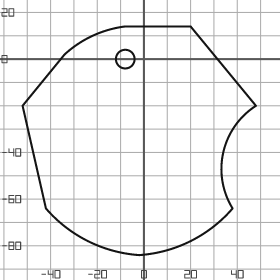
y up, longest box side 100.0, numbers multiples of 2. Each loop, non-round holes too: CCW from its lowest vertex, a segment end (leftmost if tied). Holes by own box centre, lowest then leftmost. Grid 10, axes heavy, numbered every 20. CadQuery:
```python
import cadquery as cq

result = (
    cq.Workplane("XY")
    .moveTo(-2.0, -84.0)
    .threePointArc((20.0, -78.0), (38.0, -64.0))
    .threePointArc((34.0, -40.0), (48.0, -20.0))
    .lineTo(20.0, 14.0)
    .lineTo(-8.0, 14.0)
    .threePointArc((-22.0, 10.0), (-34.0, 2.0))
    .lineTo(-52.0, -20.0)
    .lineTo(-42.0, -64.0)
    .threePointArc((-24.0, -78.0), (-2.0, -84.0))
    .close()
    .moveTo(-8.0, 0.0)
    .circle(4.0)
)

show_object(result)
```